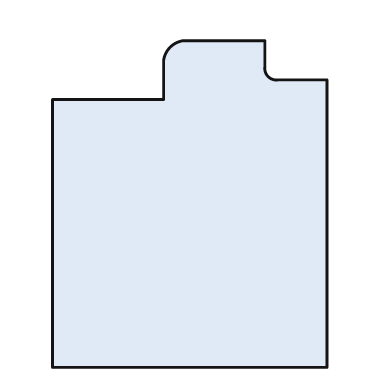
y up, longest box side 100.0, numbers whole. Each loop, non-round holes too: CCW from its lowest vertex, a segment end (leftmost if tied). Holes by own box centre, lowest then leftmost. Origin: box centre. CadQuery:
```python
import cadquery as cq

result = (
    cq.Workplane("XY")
    .moveTo(-42.0, -50.0)
    .lineTo(42.0, -50.0)
    .lineTo(42.0, 38.0)
    .lineTo(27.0, 38.0)
    .threePointArc((24.0, 39.0), (23.0, 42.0))
    .lineTo(23.0, 50.0)
    .lineTo(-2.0, 50.0)
    .threePointArc((-6.0, 48.0), (-8.0, 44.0))
    .lineTo(-8.0, 32.0)
    .lineTo(-42.0, 32.0)
    .close()
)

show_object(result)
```